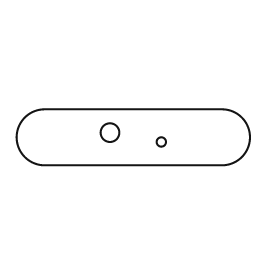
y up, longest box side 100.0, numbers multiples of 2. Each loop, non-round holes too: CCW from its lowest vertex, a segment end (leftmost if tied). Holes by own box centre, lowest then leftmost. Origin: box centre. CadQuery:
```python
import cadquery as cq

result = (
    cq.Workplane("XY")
    .moveTo(-38.0, -12.0)
    .lineTo(38.0, -12.0)
    .threePointArc((50.0, 0.0), (38.0, 12.0))
    .lineTo(-38.0, 12.0)
    .threePointArc((-50.0, 0.0), (-38.0, -12.0))
    .close()
    .moveTo(12.0, -2.0)
    .circle(2.0)
    .moveTo(-10.0, 2.0)
    .circle(4.0)
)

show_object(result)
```